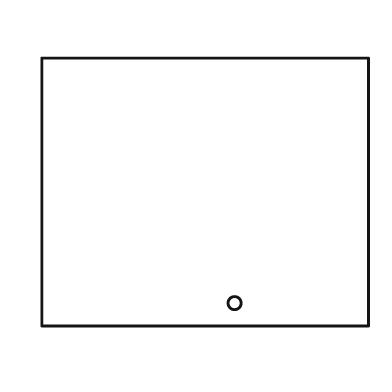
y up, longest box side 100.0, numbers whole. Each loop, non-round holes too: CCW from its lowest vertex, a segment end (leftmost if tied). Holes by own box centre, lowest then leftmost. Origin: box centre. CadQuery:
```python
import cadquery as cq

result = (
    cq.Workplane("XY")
    .moveTo(-50.0, -41.0)
    .lineTo(50.0, -41.0)
    .lineTo(50.0, 41.0)
    .lineTo(-50.0, 41.0)
    .close()
    .moveTo(9.0, -34.0)
    .circle(2.0)
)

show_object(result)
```